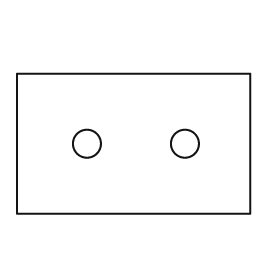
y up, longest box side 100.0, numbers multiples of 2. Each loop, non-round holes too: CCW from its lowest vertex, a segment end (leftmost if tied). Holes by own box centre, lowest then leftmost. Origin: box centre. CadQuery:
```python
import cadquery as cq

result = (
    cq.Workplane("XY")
    .moveTo(-50.0, -30.0)
    .lineTo(50.0, -30.0)
    .lineTo(50.0, 30.0)
    .lineTo(-50.0, 30.0)
    .close()
    .moveTo(-20.0, 0.0)
    .circle(6.0)
    .moveTo(22.0, 0.0)
    .circle(6.0)
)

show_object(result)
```